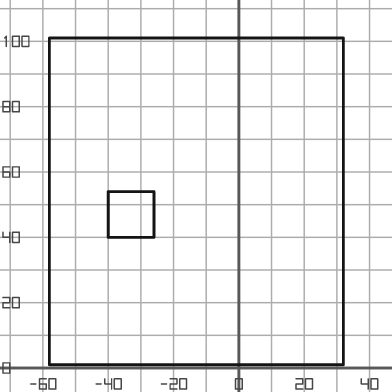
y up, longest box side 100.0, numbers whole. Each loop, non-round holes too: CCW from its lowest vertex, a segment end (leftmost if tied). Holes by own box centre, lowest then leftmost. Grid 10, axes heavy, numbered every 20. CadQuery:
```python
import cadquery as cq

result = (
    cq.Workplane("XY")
    .moveTo(-58.0, 1.0)
    .lineTo(32.0, 1.0)
    .lineTo(32.0, 101.0)
    .lineTo(-58.0, 101.0)
    .close()
    .moveTo(-40.0, 40.0)
    .lineTo(-26.0, 40.0)
    .lineTo(-26.0, 54.0)
    .lineTo(-40.0, 54.0)
    .close()
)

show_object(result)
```